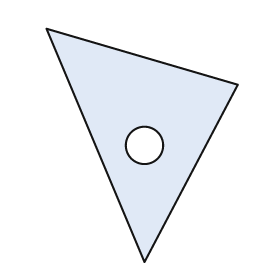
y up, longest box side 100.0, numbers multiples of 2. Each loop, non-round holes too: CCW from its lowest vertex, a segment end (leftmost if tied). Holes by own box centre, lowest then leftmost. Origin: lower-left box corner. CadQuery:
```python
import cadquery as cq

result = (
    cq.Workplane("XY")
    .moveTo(42.0, 0.0)
    .lineTo(82.0, 76.0)
    .lineTo(0.0, 100.0)
    .close()
    .moveTo(42.0, 50.0)
    .circle(8.0)
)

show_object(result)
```